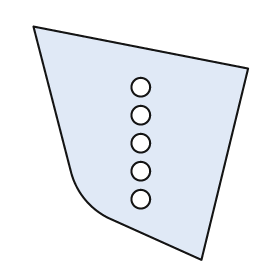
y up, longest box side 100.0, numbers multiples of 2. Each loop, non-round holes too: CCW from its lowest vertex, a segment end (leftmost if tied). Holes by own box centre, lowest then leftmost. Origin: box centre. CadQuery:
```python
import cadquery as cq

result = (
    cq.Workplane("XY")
    .moveTo(26.0, -50.0)
    .lineTo(46.0, 32.0)
    .lineTo(-46.0, 50.0)
    .lineTo(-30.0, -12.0)
    .threePointArc((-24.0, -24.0), (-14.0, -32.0))
    .close()
    .moveTo(0.0, -24.0)
    .circle(4.0)
    .moveTo(0.0, -12.0)
    .circle(4.0)
    .moveTo(0.0, 0.0)
    .circle(4.0)
    .moveTo(0.0, 12.0)
    .circle(4.0)
    .moveTo(0.0, 24.0)
    .circle(4.0)
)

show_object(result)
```